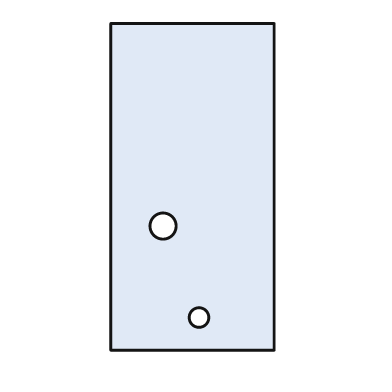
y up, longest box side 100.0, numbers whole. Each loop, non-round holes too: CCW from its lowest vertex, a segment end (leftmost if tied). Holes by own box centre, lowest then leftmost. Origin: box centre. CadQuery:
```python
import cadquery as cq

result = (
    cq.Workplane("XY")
    .moveTo(-25.0, -50.0)
    .lineTo(25.0, -50.0)
    .lineTo(25.0, 50.0)
    .lineTo(-25.0, 50.0)
    .close()
    .moveTo(2.0, -40.0)
    .circle(3.0)
    .moveTo(-9.0, -12.0)
    .circle(4.0)
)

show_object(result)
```